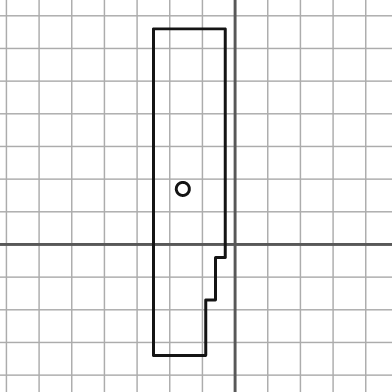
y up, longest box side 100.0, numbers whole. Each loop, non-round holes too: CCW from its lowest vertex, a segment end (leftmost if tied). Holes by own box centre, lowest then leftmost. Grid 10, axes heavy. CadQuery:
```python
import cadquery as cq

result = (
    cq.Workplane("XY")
    .moveTo(-25.0, -34.0)
    .lineTo(-9.0, -34.0)
    .lineTo(-9.0, -17.0)
    .lineTo(-6.0, -17.0)
    .lineTo(-6.0, -4.0)
    .lineTo(-3.0, -4.0)
    .lineTo(-3.0, 66.0)
    .lineTo(-25.0, 66.0)
    .close()
    .moveTo(-16.0, 17.0)
    .circle(2.0)
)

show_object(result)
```